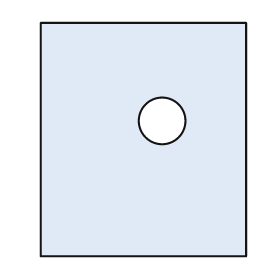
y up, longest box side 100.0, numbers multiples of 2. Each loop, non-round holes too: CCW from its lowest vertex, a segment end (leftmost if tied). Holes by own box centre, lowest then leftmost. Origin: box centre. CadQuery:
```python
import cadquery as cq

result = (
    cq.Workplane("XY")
    .moveTo(-44.0, -50.0)
    .lineTo(44.0, -50.0)
    .lineTo(44.0, 50.0)
    .lineTo(-44.0, 50.0)
    .close()
    .moveTo(8.0, 8.0)
    .circle(10.0)
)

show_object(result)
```